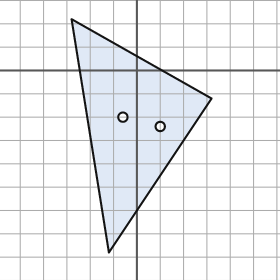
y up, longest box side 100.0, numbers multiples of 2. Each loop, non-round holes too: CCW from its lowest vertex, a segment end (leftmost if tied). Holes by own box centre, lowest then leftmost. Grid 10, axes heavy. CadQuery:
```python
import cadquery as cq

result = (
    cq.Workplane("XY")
    .moveTo(-12.0, -78.0)
    .lineTo(32.0, -12.0)
    .lineTo(-28.0, 22.0)
    .close()
    .moveTo(10.0, -24.0)
    .circle(2.0)
    .moveTo(-6.0, -20.0)
    .circle(2.0)
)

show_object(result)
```